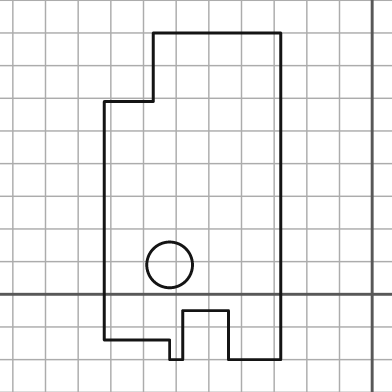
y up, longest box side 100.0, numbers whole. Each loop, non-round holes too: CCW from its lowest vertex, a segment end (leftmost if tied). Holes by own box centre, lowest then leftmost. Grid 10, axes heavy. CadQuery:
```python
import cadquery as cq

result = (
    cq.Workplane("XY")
    .moveTo(-62.0, -20.0)
    .lineTo(-58.0, -20.0)
    .lineTo(-58.0, -5.0)
    .lineTo(-44.0, -5.0)
    .lineTo(-44.0, -20.0)
    .lineTo(-28.0, -20.0)
    .lineTo(-28.0, 80.0)
    .lineTo(-67.0, 80.0)
    .lineTo(-67.0, 59.0)
    .lineTo(-82.0, 59.0)
    .lineTo(-82.0, -14.0)
    .lineTo(-62.0, -14.0)
    .close()
    .moveTo(-62.0, 9.0)
    .circle(7.0)
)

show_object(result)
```